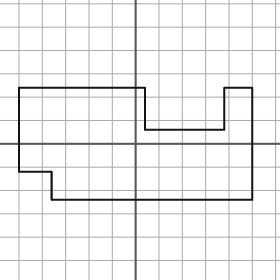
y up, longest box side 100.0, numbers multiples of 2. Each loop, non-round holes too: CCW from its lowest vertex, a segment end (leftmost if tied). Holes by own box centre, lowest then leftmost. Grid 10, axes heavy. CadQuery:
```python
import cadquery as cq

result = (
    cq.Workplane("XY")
    .moveTo(-36.0, -24.0)
    .lineTo(50.0, -24.0)
    .lineTo(50.0, 24.0)
    .lineTo(38.0, 24.0)
    .lineTo(38.0, 6.0)
    .lineTo(4.0, 6.0)
    .lineTo(4.0, 24.0)
    .lineTo(-50.0, 24.0)
    .lineTo(-50.0, -12.0)
    .lineTo(-36.0, -12.0)
    .close()
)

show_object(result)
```